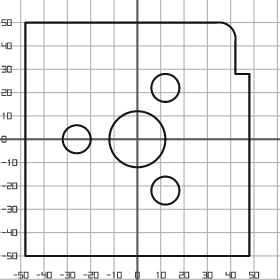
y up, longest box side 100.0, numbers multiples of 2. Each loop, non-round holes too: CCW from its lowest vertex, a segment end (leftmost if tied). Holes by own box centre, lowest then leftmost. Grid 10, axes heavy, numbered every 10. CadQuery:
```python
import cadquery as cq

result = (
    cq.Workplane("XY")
    .moveTo(-48.0, -50.0)
    .lineTo(48.0, -50.0)
    .lineTo(48.0, 28.0)
    .lineTo(42.0, 28.0)
    .lineTo(42.0, 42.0)
    .threePointArc((40.0, 48.0), (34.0, 50.0))
    .lineTo(-48.0, 50.0)
    .close()
    .moveTo(12.0, -22.0)
    .circle(6.0)
    .moveTo(-26.0, 0.0)
    .circle(6.0)
    .moveTo(0.0, 0.0)
    .circle(12.0)
    .moveTo(12.0, 22.0)
    .circle(6.0)
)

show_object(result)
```